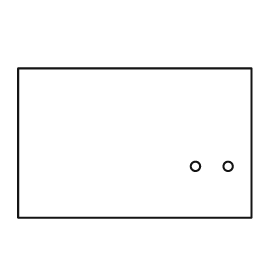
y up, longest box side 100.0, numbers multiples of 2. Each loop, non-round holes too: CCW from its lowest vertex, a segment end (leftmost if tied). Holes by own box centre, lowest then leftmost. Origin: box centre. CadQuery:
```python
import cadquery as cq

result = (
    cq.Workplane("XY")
    .moveTo(-50.0, -32.0)
    .lineTo(50.0, -32.0)
    .lineTo(50.0, 32.0)
    .lineTo(-50.0, 32.0)
    .close()
    .moveTo(26.0, -10.0)
    .circle(2.0)
    .moveTo(40.0, -10.0)
    .circle(2.0)
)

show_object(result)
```